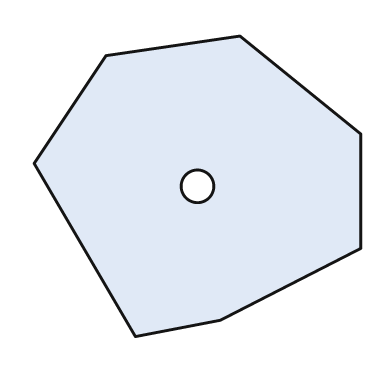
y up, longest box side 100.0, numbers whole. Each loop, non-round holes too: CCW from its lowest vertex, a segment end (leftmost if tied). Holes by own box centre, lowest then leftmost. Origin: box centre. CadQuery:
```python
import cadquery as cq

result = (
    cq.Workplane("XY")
    .moveTo(-19.0, -46.0)
    .lineTo(7.0, -41.0)
    .lineTo(50.0, -19.0)
    .lineTo(50.0, 16.0)
    .lineTo(13.0, 46.0)
    .lineTo(-28.0, 40.0)
    .lineTo(-50.0, 7.0)
    .close()
    .moveTo(0.0, 0.0)
    .circle(5.0)
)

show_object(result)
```